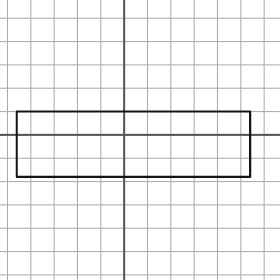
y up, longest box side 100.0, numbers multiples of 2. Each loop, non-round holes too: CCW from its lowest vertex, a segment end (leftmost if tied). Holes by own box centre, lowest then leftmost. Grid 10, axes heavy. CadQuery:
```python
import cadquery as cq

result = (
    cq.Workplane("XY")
    .moveTo(-46.0, -18.0)
    .lineTo(54.0, -18.0)
    .lineTo(54.0, 10.0)
    .lineTo(-46.0, 10.0)
    .close()
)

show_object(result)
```